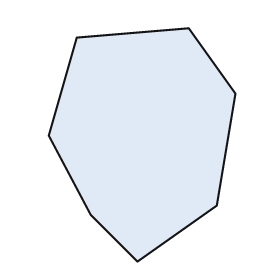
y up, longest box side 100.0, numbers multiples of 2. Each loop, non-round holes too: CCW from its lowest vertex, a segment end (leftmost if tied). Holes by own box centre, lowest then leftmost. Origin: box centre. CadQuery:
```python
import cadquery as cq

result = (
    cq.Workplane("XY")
    .moveTo(-2.0, -50.0)
    .lineTo(32.0, -26.0)
    .lineTo(40.0, 22.0)
    .lineTo(20.0, 50.0)
    .lineTo(-28.0, 46.0)
    .lineTo(-40.0, 4.0)
    .lineTo(-22.0, -30.0)
    .close()
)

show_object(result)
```